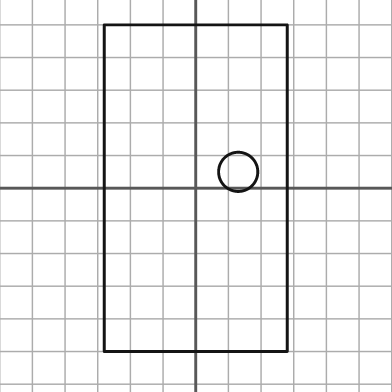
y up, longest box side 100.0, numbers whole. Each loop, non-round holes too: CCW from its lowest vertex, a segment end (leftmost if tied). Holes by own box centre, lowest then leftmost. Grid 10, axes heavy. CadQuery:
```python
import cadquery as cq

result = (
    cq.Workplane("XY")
    .moveTo(-28.0, -50.0)
    .lineTo(28.0, -50.0)
    .lineTo(28.0, 50.0)
    .lineTo(-28.0, 50.0)
    .close()
    .moveTo(13.0, 5.0)
    .circle(6.0)
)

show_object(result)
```